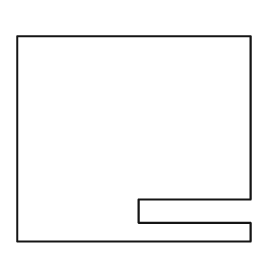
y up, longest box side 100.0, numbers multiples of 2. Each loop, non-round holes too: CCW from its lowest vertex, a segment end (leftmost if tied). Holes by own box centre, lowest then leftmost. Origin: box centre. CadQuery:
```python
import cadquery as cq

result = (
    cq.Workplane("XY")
    .moveTo(-50.0, -44.0)
    .lineTo(50.0, -44.0)
    .lineTo(50.0, -36.0)
    .lineTo(2.0, -36.0)
    .lineTo(2.0, -26.0)
    .lineTo(50.0, -26.0)
    .lineTo(50.0, 44.0)
    .lineTo(-50.0, 44.0)
    .close()
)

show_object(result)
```